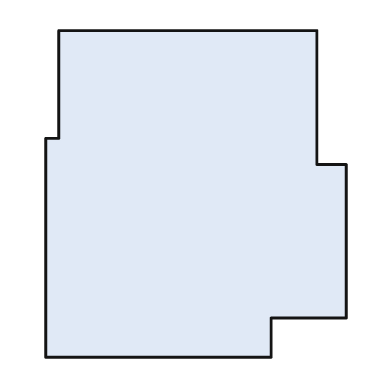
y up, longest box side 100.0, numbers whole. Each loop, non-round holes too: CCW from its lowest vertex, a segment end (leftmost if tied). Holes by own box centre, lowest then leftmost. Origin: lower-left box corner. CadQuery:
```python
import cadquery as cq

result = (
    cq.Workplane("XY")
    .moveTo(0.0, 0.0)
    .lineTo(69.0, 0.0)
    .lineTo(69.0, 12.0)
    .lineTo(92.0, 12.0)
    .lineTo(92.0, 59.0)
    .lineTo(83.0, 59.0)
    .lineTo(83.0, 100.0)
    .lineTo(4.0, 100.0)
    .lineTo(4.0, 67.0)
    .lineTo(0.0, 67.0)
    .close()
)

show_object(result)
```